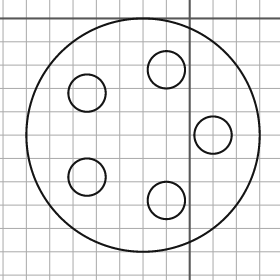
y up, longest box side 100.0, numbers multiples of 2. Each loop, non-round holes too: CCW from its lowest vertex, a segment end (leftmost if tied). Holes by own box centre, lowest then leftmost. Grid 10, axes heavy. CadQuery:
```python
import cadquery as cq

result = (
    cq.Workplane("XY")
    .moveTo(-20.0, -50.0)
    .circle(50.0)
    .moveTo(-10.0, -78.0)
    .circle(8.0)
    .moveTo(-44.0, -68.0)
    .circle(8.0)
    .moveTo(10.0, -50.0)
    .circle(8.0)
    .moveTo(-44.0, -32.0)
    .circle(8.0)
    .moveTo(-10.0, -22.0)
    .circle(8.0)
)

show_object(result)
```